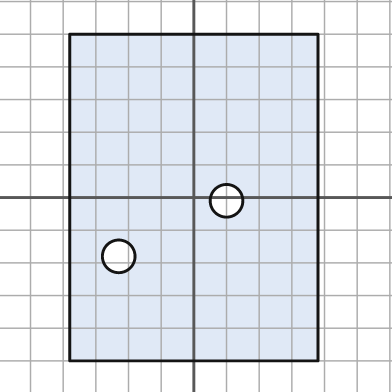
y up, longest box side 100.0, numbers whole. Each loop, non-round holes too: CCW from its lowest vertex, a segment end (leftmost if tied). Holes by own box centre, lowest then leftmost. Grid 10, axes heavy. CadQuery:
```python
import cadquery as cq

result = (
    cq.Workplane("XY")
    .moveTo(-38.0, -50.0)
    .lineTo(38.0, -50.0)
    .lineTo(38.0, 50.0)
    .lineTo(-38.0, 50.0)
    .close()
    .moveTo(-23.0, -18.0)
    .circle(5.0)
    .moveTo(10.0, -1.0)
    .circle(5.0)
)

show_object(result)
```